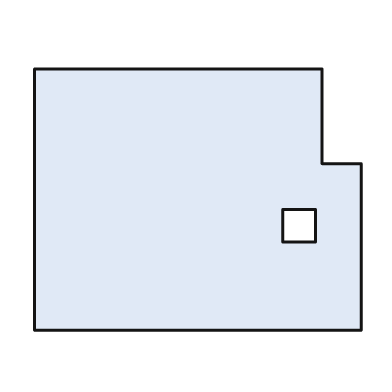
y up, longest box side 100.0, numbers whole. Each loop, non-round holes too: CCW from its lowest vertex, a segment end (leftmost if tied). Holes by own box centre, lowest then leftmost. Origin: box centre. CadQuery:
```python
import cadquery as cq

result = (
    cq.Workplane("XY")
    .moveTo(-50.0, -40.0)
    .lineTo(50.0, -40.0)
    .lineTo(50.0, 11.0)
    .lineTo(38.0, 11.0)
    .lineTo(38.0, 40.0)
    .lineTo(-50.0, 40.0)
    .close()
    .moveTo(26.0, -13.0)
    .lineTo(36.0, -13.0)
    .lineTo(36.0, -3.0)
    .lineTo(26.0, -3.0)
    .close()
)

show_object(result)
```